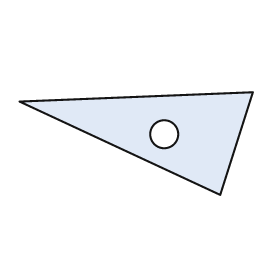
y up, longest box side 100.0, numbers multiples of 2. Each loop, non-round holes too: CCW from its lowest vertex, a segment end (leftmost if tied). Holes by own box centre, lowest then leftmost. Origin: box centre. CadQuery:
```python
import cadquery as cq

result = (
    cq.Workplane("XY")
    .moveTo(36.0, -22.0)
    .lineTo(50.0, 22.0)
    .lineTo(-50.0, 18.0)
    .close()
    .moveTo(12.0, 4.0)
    .circle(6.0)
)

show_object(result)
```